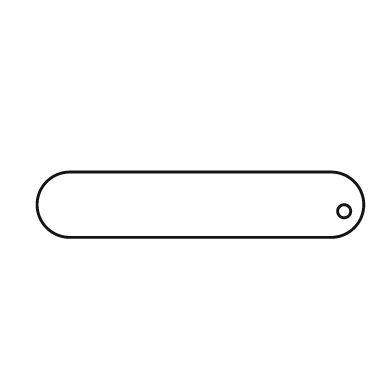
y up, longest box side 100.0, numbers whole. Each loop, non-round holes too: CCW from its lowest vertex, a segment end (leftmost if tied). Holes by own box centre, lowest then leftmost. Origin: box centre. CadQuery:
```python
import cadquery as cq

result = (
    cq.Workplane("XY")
    .moveTo(-40.0, -10.0)
    .lineTo(40.0, -10.0)
    .threePointArc((50.0, 0.0), (40.0, 10.0))
    .lineTo(-40.0, 10.0)
    .threePointArc((-50.0, 0.0), (-40.0, -10.0))
    .close()
    .moveTo(44.0, -2.0)
    .circle(2.0)
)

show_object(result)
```